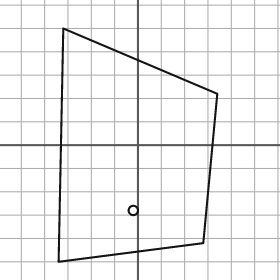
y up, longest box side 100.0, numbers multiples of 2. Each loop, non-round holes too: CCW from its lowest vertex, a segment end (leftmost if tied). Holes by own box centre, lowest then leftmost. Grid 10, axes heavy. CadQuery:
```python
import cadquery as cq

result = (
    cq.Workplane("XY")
    .moveTo(-34.0, -50.0)
    .lineTo(28.0, -42.0)
    .lineTo(34.0, 22.0)
    .lineTo(-32.0, 50.0)
    .close()
    .moveTo(-2.0, -28.0)
    .circle(2.0)
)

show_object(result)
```